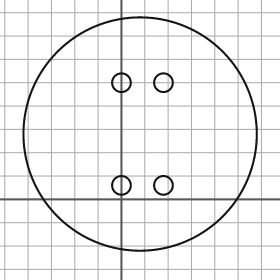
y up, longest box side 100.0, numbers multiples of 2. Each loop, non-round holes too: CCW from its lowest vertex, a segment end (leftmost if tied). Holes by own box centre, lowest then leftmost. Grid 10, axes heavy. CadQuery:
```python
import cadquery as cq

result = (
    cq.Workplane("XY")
    .moveTo(8.0, 28.0)
    .circle(50.0)
    .moveTo(0.0, 6.0)
    .circle(4.0)
    .moveTo(18.0, 6.0)
    .circle(4.0)
    .moveTo(0.0, 50.0)
    .circle(4.0)
    .moveTo(18.0, 50.0)
    .circle(4.0)
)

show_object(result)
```